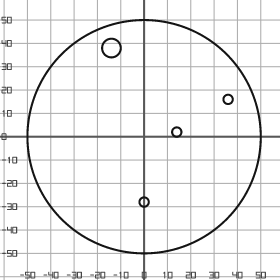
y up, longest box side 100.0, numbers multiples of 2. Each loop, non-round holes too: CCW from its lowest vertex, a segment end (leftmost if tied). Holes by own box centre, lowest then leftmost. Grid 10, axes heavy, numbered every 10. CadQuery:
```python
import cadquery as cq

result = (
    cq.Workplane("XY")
    .moveTo(0.0, 0.0)
    .circle(50.0)
    .moveTo(0.0, -28.0)
    .circle(2.0)
    .moveTo(14.0, 2.0)
    .circle(2.0)
    .moveTo(36.0, 16.0)
    .circle(2.0)
    .moveTo(-14.0, 38.0)
    .circle(4.0)
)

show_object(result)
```